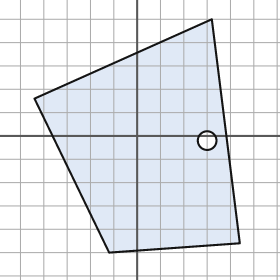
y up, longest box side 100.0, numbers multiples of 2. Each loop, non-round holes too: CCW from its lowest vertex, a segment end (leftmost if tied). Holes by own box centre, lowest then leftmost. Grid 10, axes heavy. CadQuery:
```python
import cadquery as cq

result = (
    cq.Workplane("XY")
    .moveTo(-12.0, -50.0)
    .lineTo(44.0, -46.0)
    .lineTo(32.0, 50.0)
    .lineTo(-44.0, 16.0)
    .close()
    .moveTo(30.0, -2.0)
    .circle(4.0)
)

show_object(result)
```